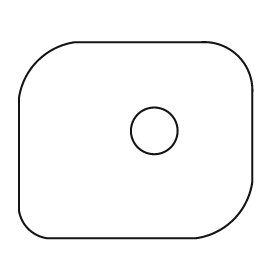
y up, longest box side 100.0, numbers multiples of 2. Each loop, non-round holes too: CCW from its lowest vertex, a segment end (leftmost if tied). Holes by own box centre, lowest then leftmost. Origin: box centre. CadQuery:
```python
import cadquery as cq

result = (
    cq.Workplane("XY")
    .moveTo(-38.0, -42.0)
    .lineTo(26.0, -42.0)
    .threePointArc((42.0, -34.0), (50.0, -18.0))
    .lineTo(50.0, 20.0)
    .threePointArc((44.0, 36.0), (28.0, 42.0))
    .lineTo(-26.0, 42.0)
    .threePointArc((-42.0, 34.0), (-50.0, 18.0))
    .lineTo(-50.0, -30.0)
    .threePointArc((-46.0, -38.0), (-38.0, -42.0))
    .close()
    .moveTo(8.0, 4.0)
    .circle(10.0)
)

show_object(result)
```